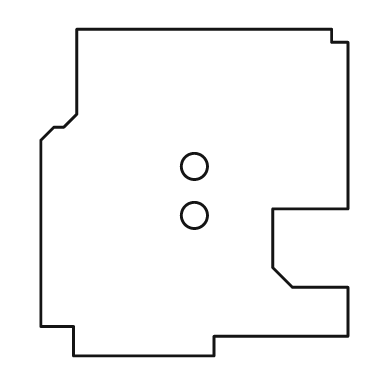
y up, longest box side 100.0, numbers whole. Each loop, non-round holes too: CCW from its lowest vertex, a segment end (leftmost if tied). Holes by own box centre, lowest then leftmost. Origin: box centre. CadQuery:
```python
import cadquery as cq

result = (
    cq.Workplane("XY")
    .moveTo(-37.0, -50.0)
    .lineTo(6.0, -50.0)
    .lineTo(6.0, -44.0)
    .lineTo(47.0, -44.0)
    .lineTo(47.0, -29.0)
    .lineTo(30.0, -29.0)
    .lineTo(24.0, -23.0)
    .lineTo(24.0, -5.0)
    .lineTo(47.0, -5.0)
    .lineTo(47.0, 46.0)
    .lineTo(42.0, 46.0)
    .lineTo(42.0, 50.0)
    .lineTo(-36.0, 50.0)
    .lineTo(-36.0, 24.0)
    .lineTo(-40.0, 20.0)
    .lineTo(-43.0, 20.0)
    .lineTo(-47.0, 16.0)
    .lineTo(-47.0, -41.0)
    .lineTo(-37.0, -41.0)
    .close()
    .moveTo(0.0, -7.0)
    .circle(4.0)
    .moveTo(0.0, 8.0)
    .circle(4.0)
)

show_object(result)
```